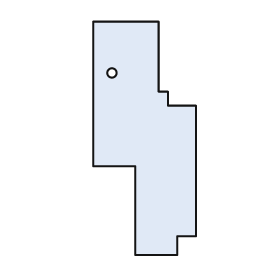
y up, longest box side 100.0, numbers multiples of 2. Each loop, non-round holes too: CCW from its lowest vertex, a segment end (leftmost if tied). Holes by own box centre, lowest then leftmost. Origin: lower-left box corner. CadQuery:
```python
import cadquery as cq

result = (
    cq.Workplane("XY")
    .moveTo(18.0, 0.0)
    .lineTo(36.0, 0.0)
    .lineTo(36.0, 8.0)
    .lineTo(44.0, 8.0)
    .lineTo(44.0, 64.0)
    .lineTo(32.0, 64.0)
    .lineTo(32.0, 70.0)
    .lineTo(28.0, 70.0)
    .lineTo(28.0, 100.0)
    .lineTo(0.0, 100.0)
    .lineTo(0.0, 38.0)
    .lineTo(18.0, 38.0)
    .close()
    .moveTo(8.0, 78.0)
    .circle(2.0)
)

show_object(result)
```